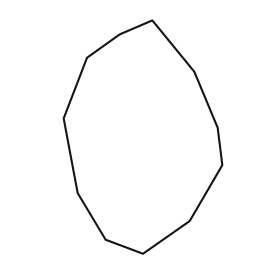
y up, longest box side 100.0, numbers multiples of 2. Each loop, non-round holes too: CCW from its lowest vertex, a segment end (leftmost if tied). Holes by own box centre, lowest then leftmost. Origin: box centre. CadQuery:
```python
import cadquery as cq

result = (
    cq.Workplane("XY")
    .moveTo(0.0, -50.0)
    .lineTo(20.0, -36.0)
    .lineTo(34.0, -12.0)
    .lineTo(32.0, 4.0)
    .lineTo(22.0, 28.0)
    .lineTo(4.0, 50.0)
    .lineTo(-10.0, 44.0)
    .lineTo(-24.0, 34.0)
    .lineTo(-34.0, 8.0)
    .lineTo(-28.0, -24.0)
    .lineTo(-16.0, -44.0)
    .close()
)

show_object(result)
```